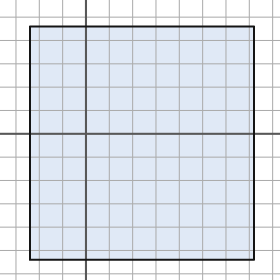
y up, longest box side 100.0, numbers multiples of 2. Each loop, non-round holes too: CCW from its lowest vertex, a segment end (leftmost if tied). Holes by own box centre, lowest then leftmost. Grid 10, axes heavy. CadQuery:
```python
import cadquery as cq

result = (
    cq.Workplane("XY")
    .moveTo(-24.0, -54.0)
    .lineTo(72.0, -54.0)
    .lineTo(72.0, 46.0)
    .lineTo(-24.0, 46.0)
    .close()
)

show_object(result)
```